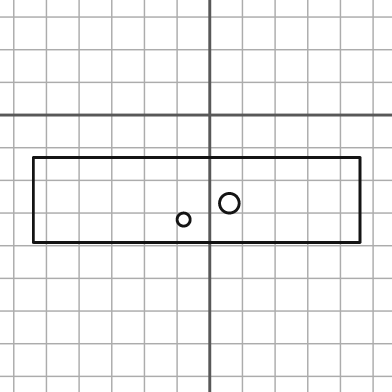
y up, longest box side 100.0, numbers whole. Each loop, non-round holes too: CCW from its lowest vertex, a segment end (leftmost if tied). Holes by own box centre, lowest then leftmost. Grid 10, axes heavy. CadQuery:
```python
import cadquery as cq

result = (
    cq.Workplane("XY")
    .moveTo(-54.0, -39.0)
    .lineTo(46.0, -39.0)
    .lineTo(46.0, -13.0)
    .lineTo(-54.0, -13.0)
    .close()
    .moveTo(-8.0, -32.0)
    .circle(2.0)
    .moveTo(6.0, -27.0)
    .circle(3.0)
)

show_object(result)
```